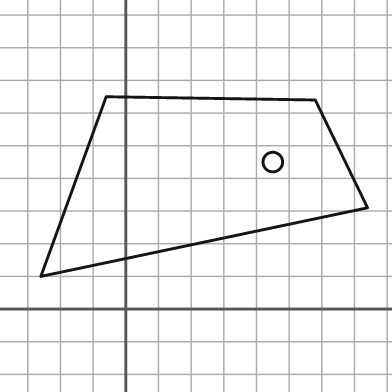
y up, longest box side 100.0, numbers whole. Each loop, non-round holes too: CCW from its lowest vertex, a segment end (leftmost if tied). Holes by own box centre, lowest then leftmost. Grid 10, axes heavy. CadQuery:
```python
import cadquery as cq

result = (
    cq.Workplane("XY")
    .moveTo(-26.0, 10.0)
    .lineTo(74.0, 31.0)
    .lineTo(58.0, 64.0)
    .lineTo(-6.0, 65.0)
    .close()
    .moveTo(45.0, 45.0)
    .circle(3.0)
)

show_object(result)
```